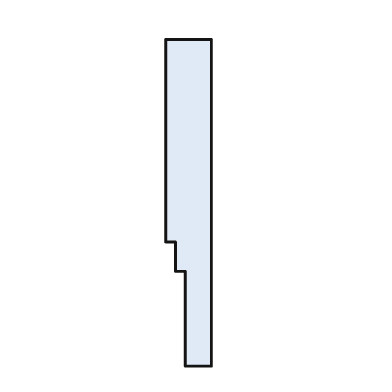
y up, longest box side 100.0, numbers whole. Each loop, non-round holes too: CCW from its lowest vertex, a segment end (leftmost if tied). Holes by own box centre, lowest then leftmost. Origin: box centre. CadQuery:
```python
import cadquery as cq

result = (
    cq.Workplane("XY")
    .moveTo(-1.0, -50.0)
    .lineTo(7.0, -50.0)
    .lineTo(7.0, 50.0)
    .lineTo(-7.0, 50.0)
    .lineTo(-7.0, -12.0)
    .lineTo(-4.0, -12.0)
    .lineTo(-4.0, -21.0)
    .lineTo(-1.0, -21.0)
    .close()
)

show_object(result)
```